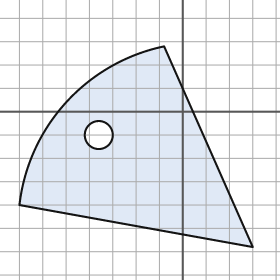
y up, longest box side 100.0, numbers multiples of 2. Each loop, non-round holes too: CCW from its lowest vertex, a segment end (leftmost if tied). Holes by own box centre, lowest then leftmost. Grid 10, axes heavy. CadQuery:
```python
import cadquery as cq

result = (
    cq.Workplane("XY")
    .moveTo(30.0, -58.0)
    .lineTo(-8.0, 28.0)
    .threePointArc((-50.0, 4.0), (-70.0, -40.0))
    .close()
    .moveTo(-36.0, -10.0)
    .circle(6.0)
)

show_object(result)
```